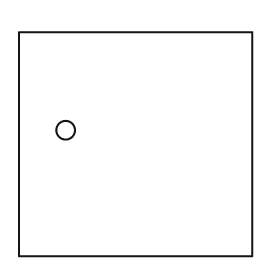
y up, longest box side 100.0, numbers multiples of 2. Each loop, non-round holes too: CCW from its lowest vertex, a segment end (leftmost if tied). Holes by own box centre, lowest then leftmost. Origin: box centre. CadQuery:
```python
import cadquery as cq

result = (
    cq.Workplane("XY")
    .moveTo(-50.0, -48.0)
    .lineTo(50.0, -48.0)
    .lineTo(50.0, 48.0)
    .lineTo(-50.0, 48.0)
    .close()
    .moveTo(-30.0, 6.0)
    .circle(4.0)
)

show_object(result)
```